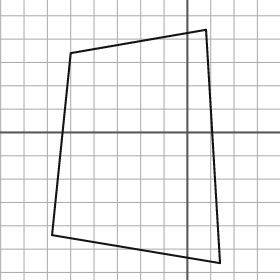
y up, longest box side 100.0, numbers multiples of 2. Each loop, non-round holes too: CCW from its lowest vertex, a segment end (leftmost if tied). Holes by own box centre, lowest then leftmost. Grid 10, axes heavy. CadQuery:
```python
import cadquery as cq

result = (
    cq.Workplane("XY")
    .moveTo(14.0, -56.0)
    .lineTo(8.0, 44.0)
    .lineTo(-50.0, 34.0)
    .lineTo(-58.0, -44.0)
    .close()
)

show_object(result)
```